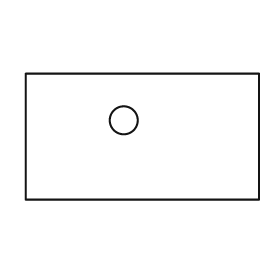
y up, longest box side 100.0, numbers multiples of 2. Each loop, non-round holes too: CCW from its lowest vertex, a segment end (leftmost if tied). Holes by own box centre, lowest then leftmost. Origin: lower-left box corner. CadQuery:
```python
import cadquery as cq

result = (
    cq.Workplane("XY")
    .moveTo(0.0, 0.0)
    .lineTo(100.0, 0.0)
    .lineTo(100.0, 54.0)
    .lineTo(0.0, 54.0)
    .close()
    .moveTo(42.0, 34.0)
    .circle(6.0)
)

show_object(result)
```